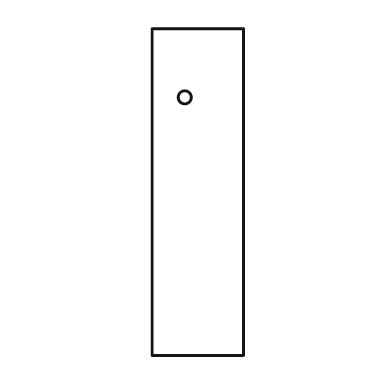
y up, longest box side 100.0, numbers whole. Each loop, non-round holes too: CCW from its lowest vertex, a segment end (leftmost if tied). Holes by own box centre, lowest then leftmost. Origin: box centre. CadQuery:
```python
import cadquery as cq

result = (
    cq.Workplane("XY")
    .moveTo(-14.0, -50.0)
    .lineTo(14.0, -50.0)
    .lineTo(14.0, 50.0)
    .lineTo(-14.0, 50.0)
    .close()
    .moveTo(-4.0, 29.0)
    .circle(2.0)
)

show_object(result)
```